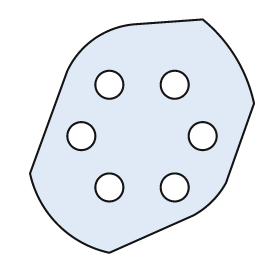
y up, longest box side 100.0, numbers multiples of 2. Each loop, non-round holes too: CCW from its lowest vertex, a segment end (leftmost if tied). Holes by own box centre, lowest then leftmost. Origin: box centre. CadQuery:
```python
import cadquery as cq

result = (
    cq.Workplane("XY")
    .moveTo(-14.0, -50.0)
    .lineTo(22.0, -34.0)
    .threePointArc((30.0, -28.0), (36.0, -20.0))
    .lineTo(48.0, 14.0)
    .threePointArc((40.0, 34.0), (26.0, 50.0))
    .lineTo(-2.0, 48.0)
    .threePointArc((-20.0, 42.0), (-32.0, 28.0))
    .lineTo(-48.0, -16.0)
    .threePointArc((-36.0, -38.0), (-14.0, -50.0))
    .close()
    .moveTo(-14.0, -22.0)
    .circle(6.0)
    .moveTo(14.0, -22.0)
    .circle(6.0)
    .moveTo(-26.0, 0.0)
    .circle(6.0)
    .moveTo(26.0, 0.0)
    .circle(6.0)
    .moveTo(-14.0, 22.0)
    .circle(6.0)
    .moveTo(14.0, 22.0)
    .circle(6.0)
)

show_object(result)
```